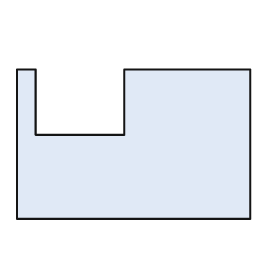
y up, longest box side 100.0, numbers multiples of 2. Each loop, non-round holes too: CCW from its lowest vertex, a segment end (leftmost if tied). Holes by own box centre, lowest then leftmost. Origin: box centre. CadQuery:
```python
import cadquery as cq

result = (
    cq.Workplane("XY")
    .moveTo(-50.0, -32.0)
    .lineTo(50.0, -32.0)
    .lineTo(50.0, 32.0)
    .lineTo(-4.0, 32.0)
    .lineTo(-4.0, 4.0)
    .lineTo(-42.0, 4.0)
    .lineTo(-42.0, 32.0)
    .lineTo(-50.0, 32.0)
    .close()
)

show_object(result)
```